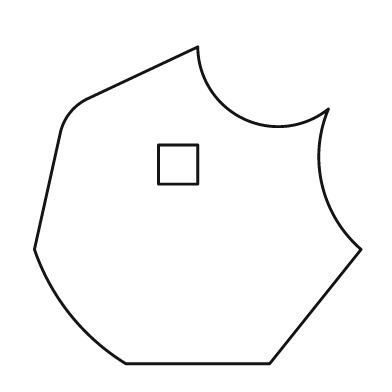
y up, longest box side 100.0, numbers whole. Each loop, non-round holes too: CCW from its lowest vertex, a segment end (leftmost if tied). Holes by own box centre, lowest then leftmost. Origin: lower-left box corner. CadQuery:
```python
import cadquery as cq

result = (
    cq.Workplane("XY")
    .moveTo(28.0, 0.0)
    .lineTo(72.0, 0.0)
    .lineTo(100.0, 35.0)
    .threePointArc((88.0, 55.0), (90.0, 78.0))
    .threePointArc((64.0, 75.0), (50.0, 97.0))
    .lineTo(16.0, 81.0)
    .threePointArc((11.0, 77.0), (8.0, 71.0))
    .lineTo(0.0, 35.0)
    .threePointArc((11.0, 15.0), (28.0, 0.0))
    .close()
    .moveTo(38.0, 55.0)
    .lineTo(50.0, 55.0)
    .lineTo(50.0, 67.0)
    .lineTo(38.0, 67.0)
    .close()
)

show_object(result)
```